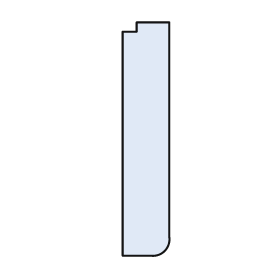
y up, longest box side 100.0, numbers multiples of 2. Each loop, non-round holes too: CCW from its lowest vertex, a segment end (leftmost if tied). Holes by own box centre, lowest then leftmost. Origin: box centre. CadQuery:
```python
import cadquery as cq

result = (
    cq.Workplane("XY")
    .moveTo(-10.0, -50.0)
    .lineTo(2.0, -50.0)
    .threePointArc((8.0, -48.0), (10.0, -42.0))
    .lineTo(10.0, 50.0)
    .lineTo(-4.0, 50.0)
    .lineTo(-4.0, 46.0)
    .lineTo(-10.0, 46.0)
    .close()
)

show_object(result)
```